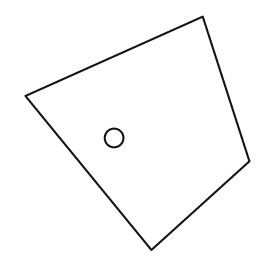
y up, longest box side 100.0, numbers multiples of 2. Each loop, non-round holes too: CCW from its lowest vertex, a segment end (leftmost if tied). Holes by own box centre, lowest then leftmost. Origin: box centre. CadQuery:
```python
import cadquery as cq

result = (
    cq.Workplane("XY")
    .moveTo(6.0, -50.0)
    .lineTo(48.0, -12.0)
    .lineTo(28.0, 50.0)
    .lineTo(-48.0, 16.0)
    .close()
    .moveTo(-10.0, -2.0)
    .circle(4.0)
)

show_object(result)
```